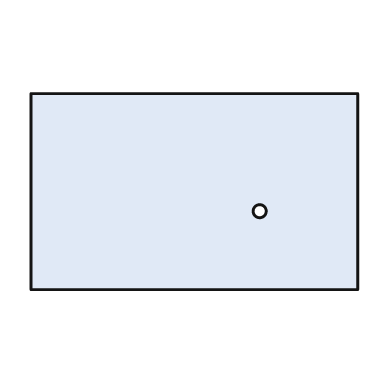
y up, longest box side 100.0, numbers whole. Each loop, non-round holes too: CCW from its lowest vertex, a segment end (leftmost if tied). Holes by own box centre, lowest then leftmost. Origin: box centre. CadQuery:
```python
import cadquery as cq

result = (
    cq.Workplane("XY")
    .moveTo(-50.0, -30.0)
    .lineTo(50.0, -30.0)
    .lineTo(50.0, 30.0)
    .lineTo(-50.0, 30.0)
    .close()
    .moveTo(20.0, -6.0)
    .circle(2.0)
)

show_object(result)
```